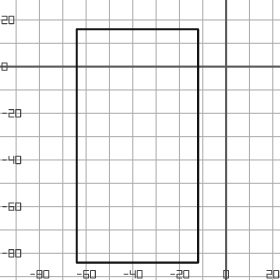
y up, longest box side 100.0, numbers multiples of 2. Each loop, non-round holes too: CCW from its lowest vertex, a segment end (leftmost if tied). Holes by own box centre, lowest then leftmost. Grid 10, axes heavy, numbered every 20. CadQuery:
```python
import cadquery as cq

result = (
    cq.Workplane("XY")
    .moveTo(-64.0, -84.0)
    .lineTo(-12.0, -84.0)
    .lineTo(-12.0, 16.0)
    .lineTo(-64.0, 16.0)
    .close()
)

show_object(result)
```